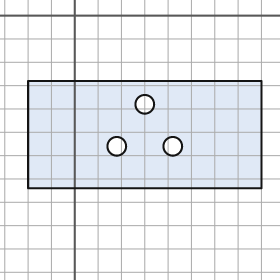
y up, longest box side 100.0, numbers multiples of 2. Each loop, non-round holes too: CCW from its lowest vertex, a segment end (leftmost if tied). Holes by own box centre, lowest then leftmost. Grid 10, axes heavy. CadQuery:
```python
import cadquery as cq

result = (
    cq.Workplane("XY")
    .moveTo(-20.0, -74.0)
    .lineTo(80.0, -74.0)
    .lineTo(80.0, -28.0)
    .lineTo(-20.0, -28.0)
    .close()
    .moveTo(18.0, -56.0)
    .circle(4.0)
    .moveTo(42.0, -56.0)
    .circle(4.0)
    .moveTo(30.0, -38.0)
    .circle(4.0)
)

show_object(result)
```